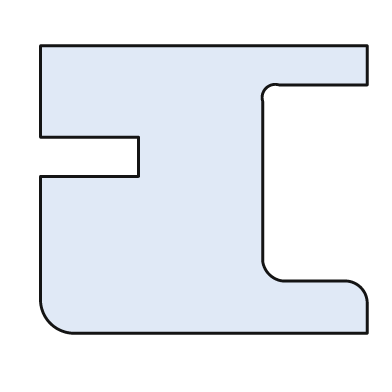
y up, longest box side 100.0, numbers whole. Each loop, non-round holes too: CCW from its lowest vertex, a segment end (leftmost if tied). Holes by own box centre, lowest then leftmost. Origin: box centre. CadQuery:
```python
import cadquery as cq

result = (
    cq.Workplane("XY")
    .moveTo(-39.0, -44.0)
    .lineTo(50.0, -44.0)
    .lineTo(50.0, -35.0)
    .threePointArc((48.0, -30.0), (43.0, -28.0))
    .lineTo(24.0, -28.0)
    .threePointArc((20.0, -26.0), (18.0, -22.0))
    .lineTo(18.0, 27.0)
    .threePointArc((19.0, 31.0), (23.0, 32.0))
    .lineTo(50.0, 32.0)
    .lineTo(50.0, 44.0)
    .lineTo(-50.0, 44.0)
    .lineTo(-50.0, 16.0)
    .lineTo(-20.0, 16.0)
    .lineTo(-20.0, 4.0)
    .lineTo(-50.0, 4.0)
    .lineTo(-50.0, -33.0)
    .threePointArc((-47.0, -41.0), (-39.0, -44.0))
    .close()
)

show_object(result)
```